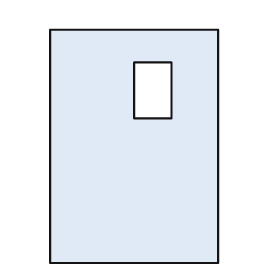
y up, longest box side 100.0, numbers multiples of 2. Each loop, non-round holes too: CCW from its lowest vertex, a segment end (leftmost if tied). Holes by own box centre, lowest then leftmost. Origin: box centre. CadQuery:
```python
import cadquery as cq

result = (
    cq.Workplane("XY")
    .moveTo(-36.0, -50.0)
    .lineTo(36.0, -50.0)
    .lineTo(36.0, 50.0)
    .lineTo(-36.0, 50.0)
    .close()
    .moveTo(0.0, 12.0)
    .lineTo(16.0, 12.0)
    .lineTo(16.0, 36.0)
    .lineTo(0.0, 36.0)
    .close()
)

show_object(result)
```